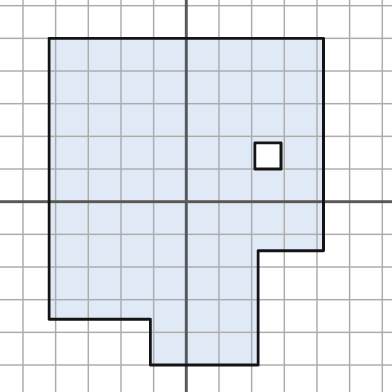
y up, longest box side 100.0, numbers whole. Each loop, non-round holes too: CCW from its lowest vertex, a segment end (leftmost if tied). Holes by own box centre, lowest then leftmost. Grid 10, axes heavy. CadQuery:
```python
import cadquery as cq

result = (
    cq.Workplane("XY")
    .moveTo(-11.0, -50.0)
    .lineTo(22.0, -50.0)
    .lineTo(22.0, -15.0)
    .lineTo(42.0, -15.0)
    .lineTo(42.0, 50.0)
    .lineTo(-42.0, 50.0)
    .lineTo(-42.0, -36.0)
    .lineTo(-11.0, -36.0)
    .close()
    .moveTo(21.0, 10.0)
    .lineTo(29.0, 10.0)
    .lineTo(29.0, 18.0)
    .lineTo(21.0, 18.0)
    .close()
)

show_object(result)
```